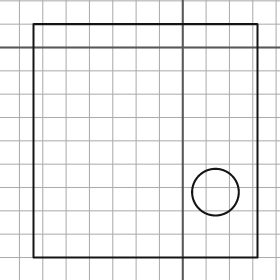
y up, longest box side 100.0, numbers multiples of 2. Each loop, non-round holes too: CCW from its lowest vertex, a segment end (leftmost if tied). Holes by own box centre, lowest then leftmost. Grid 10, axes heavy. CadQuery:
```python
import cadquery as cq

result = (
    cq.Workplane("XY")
    .moveTo(-64.0, -90.0)
    .lineTo(32.0, -90.0)
    .lineTo(32.0, 10.0)
    .lineTo(-64.0, 10.0)
    .close()
    .moveTo(14.0, -62.0)
    .circle(10.0)
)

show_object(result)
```